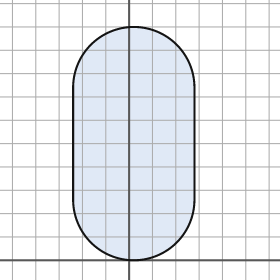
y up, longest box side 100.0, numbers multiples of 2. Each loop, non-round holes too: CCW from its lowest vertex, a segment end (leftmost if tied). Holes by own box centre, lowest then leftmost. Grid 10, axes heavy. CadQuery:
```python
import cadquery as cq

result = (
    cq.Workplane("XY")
    .moveTo(-24.0, 26.0)
    .threePointArc((2.0, 0.0), (28.0, 26.0))
    .lineTo(28.0, 74.0)
    .threePointArc((2.0, 100.0), (-24.0, 74.0))
    .close()
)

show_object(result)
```